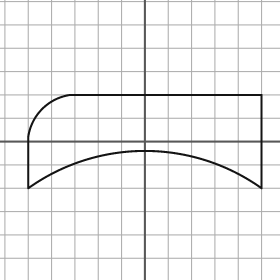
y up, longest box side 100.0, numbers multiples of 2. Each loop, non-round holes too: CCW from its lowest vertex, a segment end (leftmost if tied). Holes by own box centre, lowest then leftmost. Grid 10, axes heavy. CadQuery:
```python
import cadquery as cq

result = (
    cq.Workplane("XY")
    .moveTo(-50.0, -20.0)
    .threePointArc((0.0, -4.0), (50.0, -20.0))
    .lineTo(50.0, 20.0)
    .lineTo(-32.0, 20.0)
    .threePointArc((-44.0, 14.0), (-50.0, 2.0))
    .close()
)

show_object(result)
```